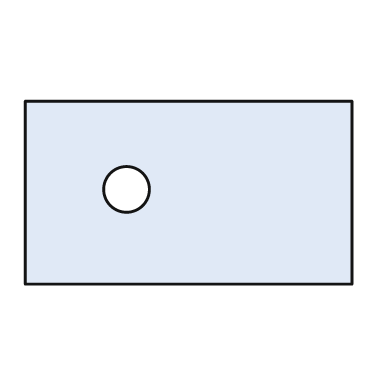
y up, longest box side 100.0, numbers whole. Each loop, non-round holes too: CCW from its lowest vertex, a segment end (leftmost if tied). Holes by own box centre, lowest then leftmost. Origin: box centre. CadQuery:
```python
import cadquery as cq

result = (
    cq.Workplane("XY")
    .moveTo(-50.0, -28.0)
    .lineTo(50.0, -28.0)
    .lineTo(50.0, 28.0)
    .lineTo(-50.0, 28.0)
    .close()
    .moveTo(-19.0, 1.0)
    .circle(7.0)
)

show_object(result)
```